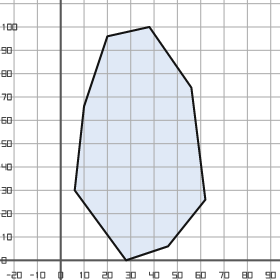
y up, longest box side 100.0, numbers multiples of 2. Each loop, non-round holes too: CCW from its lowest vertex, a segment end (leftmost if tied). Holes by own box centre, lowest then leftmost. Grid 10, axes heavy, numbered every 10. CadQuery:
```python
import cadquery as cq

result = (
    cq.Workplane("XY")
    .moveTo(28.0, 0.0)
    .lineTo(46.0, 6.0)
    .lineTo(62.0, 26.0)
    .lineTo(56.0, 74.0)
    .lineTo(38.0, 100.0)
    .lineTo(20.0, 96.0)
    .lineTo(10.0, 66.0)
    .lineTo(6.0, 30.0)
    .close()
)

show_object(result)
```